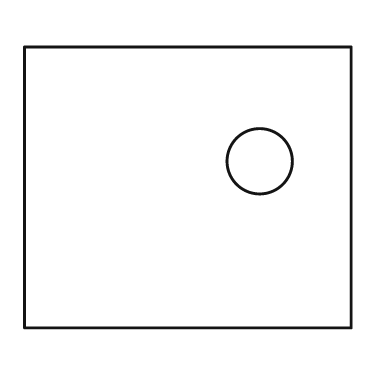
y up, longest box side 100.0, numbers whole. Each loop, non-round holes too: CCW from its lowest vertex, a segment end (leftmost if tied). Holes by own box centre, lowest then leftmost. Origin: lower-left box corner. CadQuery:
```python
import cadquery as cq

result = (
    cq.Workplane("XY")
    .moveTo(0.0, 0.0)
    .lineTo(100.0, 0.0)
    .lineTo(100.0, 86.0)
    .lineTo(0.0, 86.0)
    .close()
    .moveTo(72.0, 51.0)
    .circle(10.0)
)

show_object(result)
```